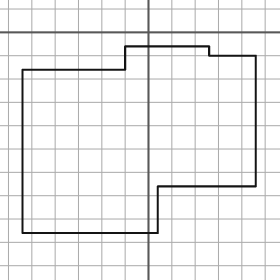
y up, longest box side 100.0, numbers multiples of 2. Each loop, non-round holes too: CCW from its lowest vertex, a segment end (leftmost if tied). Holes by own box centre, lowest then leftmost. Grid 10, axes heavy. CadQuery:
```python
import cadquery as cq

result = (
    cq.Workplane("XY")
    .moveTo(-54.0, -86.0)
    .lineTo(4.0, -86.0)
    .lineTo(4.0, -66.0)
    .lineTo(46.0, -66.0)
    .lineTo(46.0, -10.0)
    .lineTo(26.0, -10.0)
    .lineTo(26.0, -6.0)
    .lineTo(-10.0, -6.0)
    .lineTo(-10.0, -16.0)
    .lineTo(-54.0, -16.0)
    .close()
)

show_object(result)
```